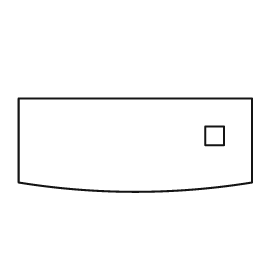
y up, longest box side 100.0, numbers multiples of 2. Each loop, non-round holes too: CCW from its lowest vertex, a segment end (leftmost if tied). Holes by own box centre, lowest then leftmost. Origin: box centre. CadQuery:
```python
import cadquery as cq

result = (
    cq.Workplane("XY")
    .moveTo(-50.0, -16.0)
    .threePointArc((0.0, -20.0), (50.0, -16.0))
    .lineTo(50.0, 20.0)
    .lineTo(-50.0, 20.0)
    .close()
    .moveTo(30.0, 0.0)
    .lineTo(38.0, 0.0)
    .lineTo(38.0, 8.0)
    .lineTo(30.0, 8.0)
    .close()
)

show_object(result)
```